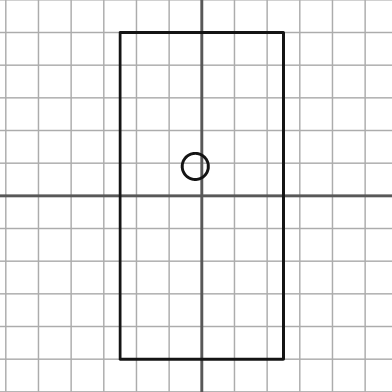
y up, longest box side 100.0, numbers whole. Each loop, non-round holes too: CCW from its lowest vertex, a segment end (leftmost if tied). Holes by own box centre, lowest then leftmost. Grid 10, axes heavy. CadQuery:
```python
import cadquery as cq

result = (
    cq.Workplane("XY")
    .moveTo(-25.0, -50.0)
    .lineTo(25.0, -50.0)
    .lineTo(25.0, 50.0)
    .lineTo(-25.0, 50.0)
    .close()
    .moveTo(-2.0, 9.0)
    .circle(4.0)
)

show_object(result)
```